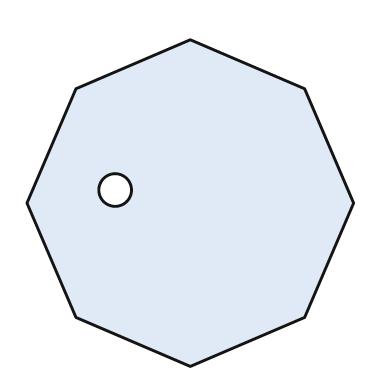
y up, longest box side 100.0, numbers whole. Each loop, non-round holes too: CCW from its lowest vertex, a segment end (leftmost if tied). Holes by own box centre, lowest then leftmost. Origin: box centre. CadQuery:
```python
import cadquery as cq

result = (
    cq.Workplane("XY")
    .moveTo(0.0, -50.0)
    .lineTo(35.0, -35.0)
    .lineTo(50.0, 0.0)
    .lineTo(35.0, 35.0)
    .lineTo(0.0, 50.0)
    .lineTo(-35.0, 35.0)
    .lineTo(-50.0, 0.0)
    .lineTo(-35.0, -35.0)
    .close()
    .moveTo(-23.0, 4.0)
    .circle(5.0)
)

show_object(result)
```